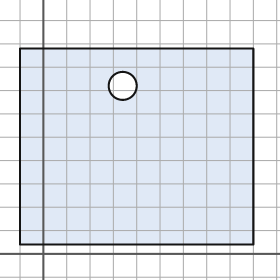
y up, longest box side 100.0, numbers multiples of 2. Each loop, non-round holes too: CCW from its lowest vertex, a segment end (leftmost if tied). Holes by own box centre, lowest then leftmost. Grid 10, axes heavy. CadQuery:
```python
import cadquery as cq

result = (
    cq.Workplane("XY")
    .moveTo(-10.0, 4.0)
    .lineTo(90.0, 4.0)
    .lineTo(90.0, 88.0)
    .lineTo(-10.0, 88.0)
    .close()
    .moveTo(34.0, 72.0)
    .circle(6.0)
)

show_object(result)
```